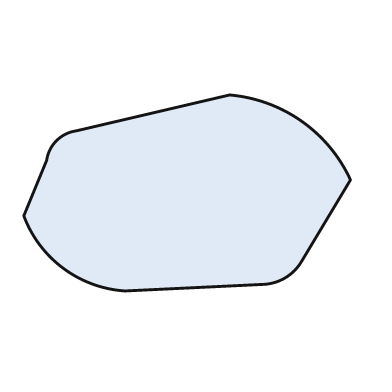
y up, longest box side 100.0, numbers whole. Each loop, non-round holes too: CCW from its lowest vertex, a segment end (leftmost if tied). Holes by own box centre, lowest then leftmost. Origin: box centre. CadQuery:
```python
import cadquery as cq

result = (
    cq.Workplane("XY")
    .moveTo(-19.0, -30.0)
    .lineTo(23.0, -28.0)
    .threePointArc((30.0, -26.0), (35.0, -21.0))
    .lineTo(50.0, 4.0)
    .threePointArc((35.0, 22.0), (13.0, 30.0))
    .lineTo(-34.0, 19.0)
    .threePointArc((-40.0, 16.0), (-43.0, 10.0))
    .lineTo(-50.0, -7.0)
    .threePointArc((-38.0, -23.0), (-19.0, -30.0))
    .close()
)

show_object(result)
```